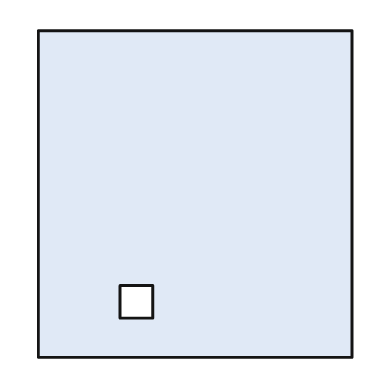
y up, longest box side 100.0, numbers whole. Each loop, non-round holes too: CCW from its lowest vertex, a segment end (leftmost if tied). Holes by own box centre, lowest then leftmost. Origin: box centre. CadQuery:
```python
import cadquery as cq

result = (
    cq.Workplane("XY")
    .moveTo(-48.0, -50.0)
    .lineTo(48.0, -50.0)
    .lineTo(48.0, 50.0)
    .lineTo(-48.0, 50.0)
    .close()
    .moveTo(-23.0, -38.0)
    .lineTo(-13.0, -38.0)
    .lineTo(-13.0, -28.0)
    .lineTo(-23.0, -28.0)
    .close()
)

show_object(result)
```